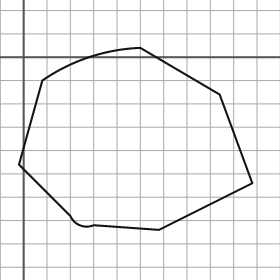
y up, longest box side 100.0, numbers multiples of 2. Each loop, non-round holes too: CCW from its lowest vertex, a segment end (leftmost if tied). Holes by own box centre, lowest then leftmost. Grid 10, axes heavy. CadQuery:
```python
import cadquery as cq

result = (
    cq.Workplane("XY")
    .moveTo(58.0, -74.0)
    .lineTo(98.0, -54.0)
    .lineTo(84.0, -16.0)
    .lineTo(50.0, 4.0)
    .threePointArc((28.0, 0.0), (8.0, -10.0))
    .lineTo(-2.0, -46.0)
    .lineTo(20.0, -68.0)
    .threePointArc((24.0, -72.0), (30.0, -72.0))
    .close()
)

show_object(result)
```